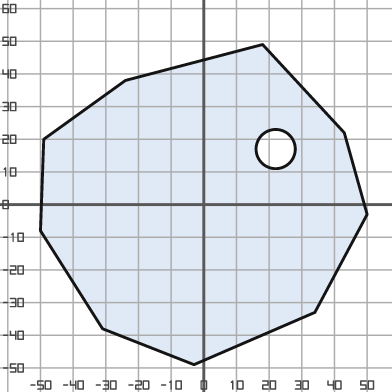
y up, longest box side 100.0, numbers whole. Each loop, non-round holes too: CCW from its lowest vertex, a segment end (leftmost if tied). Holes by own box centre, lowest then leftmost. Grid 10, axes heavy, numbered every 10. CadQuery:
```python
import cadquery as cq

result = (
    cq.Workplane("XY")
    .moveTo(-3.0, -49.0)
    .lineTo(34.0, -33.0)
    .lineTo(50.0, -3.0)
    .lineTo(43.0, 22.0)
    .lineTo(18.0, 49.0)
    .lineTo(-24.0, 38.0)
    .lineTo(-49.0, 20.0)
    .lineTo(-50.0, -8.0)
    .lineTo(-31.0, -38.0)
    .close()
    .moveTo(22.0, 17.0)
    .circle(6.0)
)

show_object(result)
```